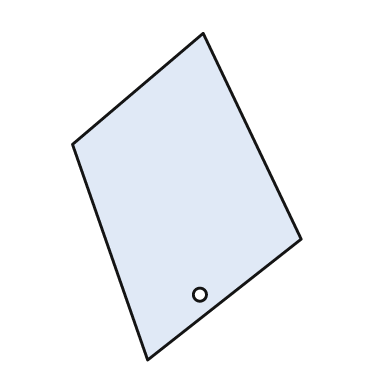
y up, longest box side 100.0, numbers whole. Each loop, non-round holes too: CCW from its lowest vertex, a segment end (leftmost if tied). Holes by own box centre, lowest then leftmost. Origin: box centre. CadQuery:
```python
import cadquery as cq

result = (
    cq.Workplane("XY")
    .moveTo(-12.0, -50.0)
    .lineTo(35.0, -13.0)
    .lineTo(5.0, 50.0)
    .lineTo(-35.0, 16.0)
    .close()
    .moveTo(4.0, -30.0)
    .circle(2.0)
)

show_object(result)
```